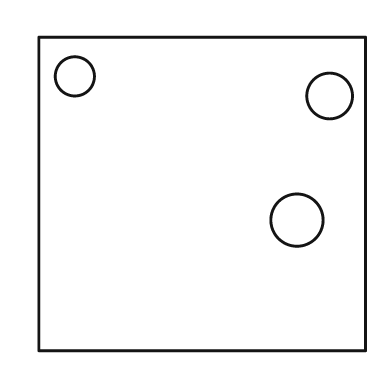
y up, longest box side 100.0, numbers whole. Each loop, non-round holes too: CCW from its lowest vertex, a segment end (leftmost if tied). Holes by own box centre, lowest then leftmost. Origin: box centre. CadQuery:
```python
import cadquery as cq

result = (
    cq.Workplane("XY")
    .moveTo(-50.0, -48.0)
    .lineTo(50.0, -48.0)
    .lineTo(50.0, 48.0)
    .lineTo(-50.0, 48.0)
    .close()
    .moveTo(29.0, -8.0)
    .circle(8.0)
    .moveTo(39.0, 30.0)
    .circle(7.0)
    .moveTo(-39.0, 36.0)
    .circle(6.0)
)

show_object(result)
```